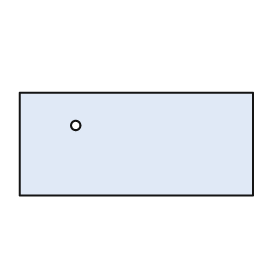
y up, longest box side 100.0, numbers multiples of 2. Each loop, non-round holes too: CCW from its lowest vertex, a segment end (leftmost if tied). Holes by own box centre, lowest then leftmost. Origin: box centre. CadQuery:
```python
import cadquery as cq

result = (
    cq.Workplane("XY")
    .moveTo(-50.0, -22.0)
    .lineTo(50.0, -22.0)
    .lineTo(50.0, 22.0)
    .lineTo(-50.0, 22.0)
    .close()
    .moveTo(-26.0, 8.0)
    .circle(2.0)
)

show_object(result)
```